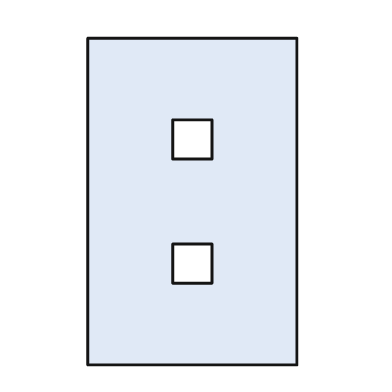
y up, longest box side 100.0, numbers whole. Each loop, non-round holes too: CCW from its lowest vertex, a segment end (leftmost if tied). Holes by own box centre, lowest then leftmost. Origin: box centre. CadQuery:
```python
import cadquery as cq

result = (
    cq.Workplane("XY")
    .moveTo(-32.0, -50.0)
    .lineTo(32.0, -50.0)
    .lineTo(32.0, 50.0)
    .lineTo(-32.0, 50.0)
    .close()
    .moveTo(-6.0, -25.0)
    .lineTo(6.0, -25.0)
    .lineTo(6.0, -13.0)
    .lineTo(-6.0, -13.0)
    .close()
    .moveTo(-6.0, 13.0)
    .lineTo(6.0, 13.0)
    .lineTo(6.0, 25.0)
    .lineTo(-6.0, 25.0)
    .close()
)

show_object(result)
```